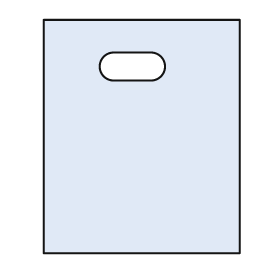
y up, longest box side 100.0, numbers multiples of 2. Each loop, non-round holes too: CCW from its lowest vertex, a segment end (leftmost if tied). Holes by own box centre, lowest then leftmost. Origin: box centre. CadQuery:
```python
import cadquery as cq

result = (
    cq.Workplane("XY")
    .moveTo(-42.0, -50.0)
    .lineTo(42.0, -50.0)
    .lineTo(42.0, 50.0)
    .lineTo(-42.0, 50.0)
    .close()
    .moveTo(-12.0, 24.0)
    .lineTo(4.0, 24.0)
    .threePointArc((10.0, 30.0), (4.0, 36.0))
    .lineTo(-12.0, 36.0)
    .threePointArc((-18.0, 30.0), (-12.0, 24.0))
    .close()
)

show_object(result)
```